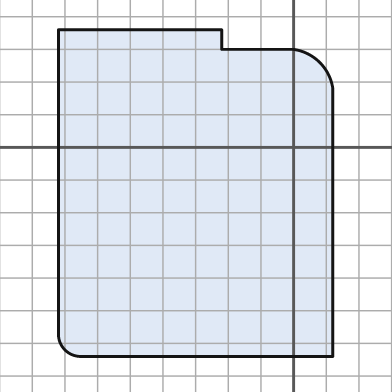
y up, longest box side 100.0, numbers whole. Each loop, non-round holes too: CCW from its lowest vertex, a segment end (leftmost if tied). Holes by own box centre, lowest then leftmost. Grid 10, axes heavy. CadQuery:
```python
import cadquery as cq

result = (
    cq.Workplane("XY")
    .moveTo(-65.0, -64.0)
    .lineTo(12.0, -64.0)
    .lineTo(12.0, 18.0)
    .threePointArc((8.0, 26.0), (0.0, 30.0))
    .lineTo(-22.0, 30.0)
    .lineTo(-22.0, 36.0)
    .lineTo(-72.0, 36.0)
    .lineTo(-72.0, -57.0)
    .threePointArc((-70.0, -62.0), (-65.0, -64.0))
    .close()
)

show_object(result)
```